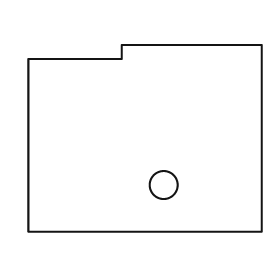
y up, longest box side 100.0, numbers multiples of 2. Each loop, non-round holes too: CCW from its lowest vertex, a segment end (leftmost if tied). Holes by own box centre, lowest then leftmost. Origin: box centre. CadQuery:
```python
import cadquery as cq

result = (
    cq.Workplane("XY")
    .moveTo(-50.0, -40.0)
    .lineTo(50.0, -40.0)
    .lineTo(50.0, 40.0)
    .lineTo(-10.0, 40.0)
    .lineTo(-10.0, 34.0)
    .lineTo(-50.0, 34.0)
    .close()
    .moveTo(8.0, -20.0)
    .circle(6.0)
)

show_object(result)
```